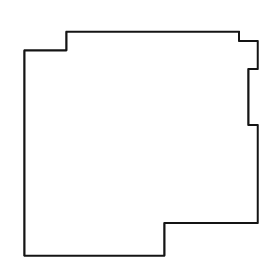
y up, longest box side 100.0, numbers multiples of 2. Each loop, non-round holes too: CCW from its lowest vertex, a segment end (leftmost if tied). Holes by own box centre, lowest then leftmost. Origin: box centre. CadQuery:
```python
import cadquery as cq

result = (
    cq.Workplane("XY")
    .moveTo(-50.0, -48.0)
    .lineTo(10.0, -48.0)
    .lineTo(10.0, -34.0)
    .lineTo(50.0, -34.0)
    .lineTo(50.0, 8.0)
    .lineTo(46.0, 8.0)
    .lineTo(46.0, 32.0)
    .lineTo(50.0, 32.0)
    .lineTo(50.0, 44.0)
    .lineTo(42.0, 44.0)
    .lineTo(42.0, 48.0)
    .lineTo(-32.0, 48.0)
    .lineTo(-32.0, 40.0)
    .lineTo(-50.0, 40.0)
    .close()
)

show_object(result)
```